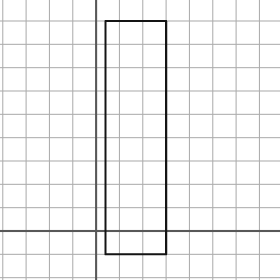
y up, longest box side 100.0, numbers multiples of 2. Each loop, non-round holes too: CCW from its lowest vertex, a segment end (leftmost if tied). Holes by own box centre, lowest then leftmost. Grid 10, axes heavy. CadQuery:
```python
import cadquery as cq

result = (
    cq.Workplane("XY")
    .moveTo(4.0, -10.0)
    .lineTo(30.0, -10.0)
    .lineTo(30.0, 90.0)
    .lineTo(4.0, 90.0)
    .close()
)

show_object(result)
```